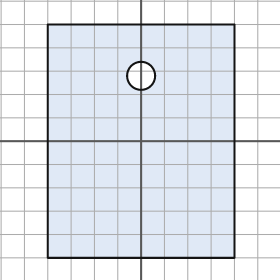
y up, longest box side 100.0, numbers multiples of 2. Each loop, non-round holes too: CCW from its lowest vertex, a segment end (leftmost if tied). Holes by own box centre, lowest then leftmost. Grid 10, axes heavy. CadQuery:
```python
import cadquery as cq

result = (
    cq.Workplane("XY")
    .moveTo(-40.0, -50.0)
    .lineTo(40.0, -50.0)
    .lineTo(40.0, 50.0)
    .lineTo(-40.0, 50.0)
    .close()
    .moveTo(0.0, 28.0)
    .circle(6.0)
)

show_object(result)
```